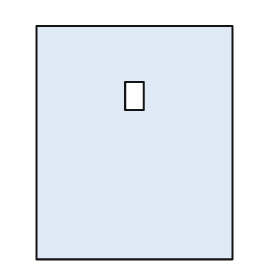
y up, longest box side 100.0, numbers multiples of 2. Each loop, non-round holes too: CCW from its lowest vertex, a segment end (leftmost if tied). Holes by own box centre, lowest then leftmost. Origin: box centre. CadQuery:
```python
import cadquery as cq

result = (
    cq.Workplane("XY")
    .moveTo(-42.0, -50.0)
    .lineTo(42.0, -50.0)
    .lineTo(42.0, 50.0)
    .lineTo(-42.0, 50.0)
    .close()
    .moveTo(-4.0, 14.0)
    .lineTo(4.0, 14.0)
    .lineTo(4.0, 26.0)
    .lineTo(-4.0, 26.0)
    .close()
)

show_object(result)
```